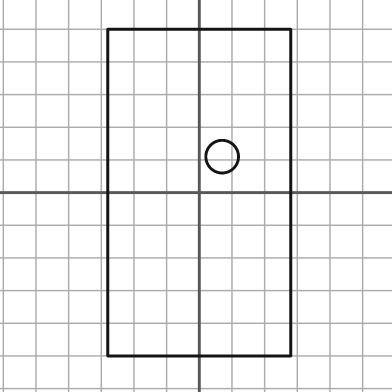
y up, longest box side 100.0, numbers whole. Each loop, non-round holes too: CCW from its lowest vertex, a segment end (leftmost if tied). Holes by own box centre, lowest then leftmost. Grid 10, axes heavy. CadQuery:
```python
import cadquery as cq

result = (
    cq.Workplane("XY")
    .moveTo(-28.0, -50.0)
    .lineTo(28.0, -50.0)
    .lineTo(28.0, 50.0)
    .lineTo(-28.0, 50.0)
    .close()
    .moveTo(7.0, 11.0)
    .circle(5.0)
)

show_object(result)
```